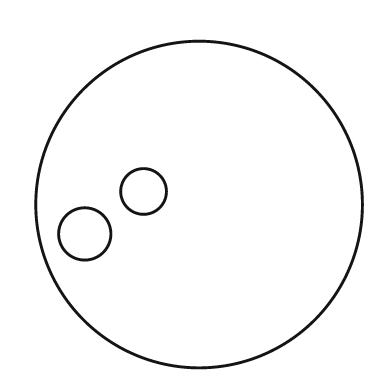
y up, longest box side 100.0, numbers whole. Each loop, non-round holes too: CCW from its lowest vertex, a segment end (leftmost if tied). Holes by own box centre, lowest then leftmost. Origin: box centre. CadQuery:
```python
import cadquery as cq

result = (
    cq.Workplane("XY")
    .moveTo(0.0, 0.0)
    .circle(50.0)
    .moveTo(-35.0, -9.0)
    .circle(8.0)
    .moveTo(-17.0, 4.0)
    .circle(7.0)
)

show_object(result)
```